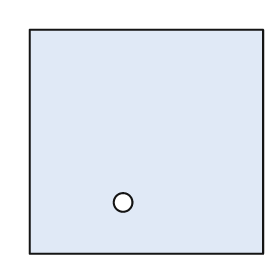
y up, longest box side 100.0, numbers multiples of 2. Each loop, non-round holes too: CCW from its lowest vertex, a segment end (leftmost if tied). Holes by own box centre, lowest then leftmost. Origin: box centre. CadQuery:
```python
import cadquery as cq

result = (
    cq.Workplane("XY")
    .moveTo(-50.0, -48.0)
    .lineTo(50.0, -48.0)
    .lineTo(50.0, 48.0)
    .lineTo(-50.0, 48.0)
    .close()
    .moveTo(-10.0, -26.0)
    .circle(4.0)
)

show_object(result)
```